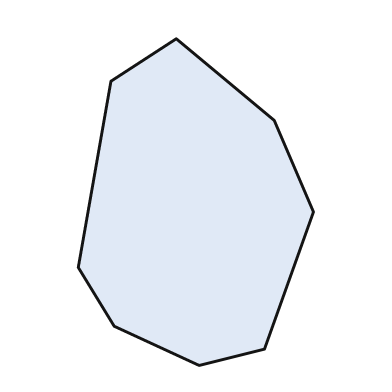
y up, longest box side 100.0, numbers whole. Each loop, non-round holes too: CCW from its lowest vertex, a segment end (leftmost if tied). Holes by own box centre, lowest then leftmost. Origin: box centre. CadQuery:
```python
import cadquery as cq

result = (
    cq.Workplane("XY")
    .moveTo(1.0, -50.0)
    .lineTo(21.0, -45.0)
    .lineTo(36.0, -3.0)
    .lineTo(24.0, 25.0)
    .lineTo(-6.0, 50.0)
    .lineTo(-26.0, 37.0)
    .lineTo(-36.0, -20.0)
    .lineTo(-25.0, -38.0)
    .close()
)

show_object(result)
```